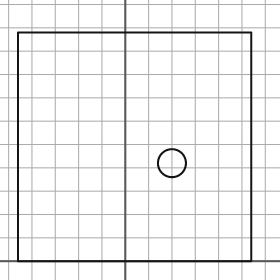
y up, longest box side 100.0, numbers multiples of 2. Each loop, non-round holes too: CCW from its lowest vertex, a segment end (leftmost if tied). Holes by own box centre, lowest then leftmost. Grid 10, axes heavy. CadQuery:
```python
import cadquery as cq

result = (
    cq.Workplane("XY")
    .moveTo(-46.0, 0.0)
    .lineTo(54.0, 0.0)
    .lineTo(54.0, 98.0)
    .lineTo(-46.0, 98.0)
    .close()
    .moveTo(20.0, 42.0)
    .circle(6.0)
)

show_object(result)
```